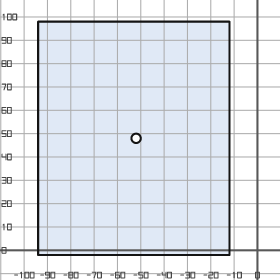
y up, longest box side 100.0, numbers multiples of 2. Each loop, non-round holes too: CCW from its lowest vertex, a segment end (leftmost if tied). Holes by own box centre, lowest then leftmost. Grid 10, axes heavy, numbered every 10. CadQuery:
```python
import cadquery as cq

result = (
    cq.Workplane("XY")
    .moveTo(-94.0, -2.0)
    .lineTo(-12.0, -2.0)
    .lineTo(-12.0, 98.0)
    .lineTo(-94.0, 98.0)
    .close()
    .moveTo(-52.0, 48.0)
    .circle(2.0)
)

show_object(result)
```